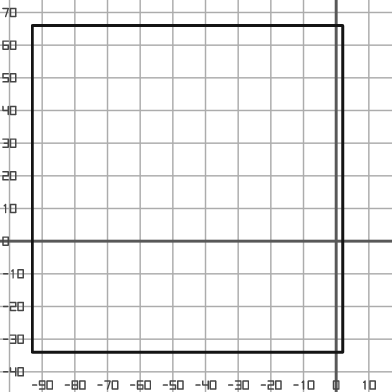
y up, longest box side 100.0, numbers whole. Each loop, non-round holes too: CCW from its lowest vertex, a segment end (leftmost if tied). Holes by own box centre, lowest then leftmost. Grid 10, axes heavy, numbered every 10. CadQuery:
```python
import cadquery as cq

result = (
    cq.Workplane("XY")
    .moveTo(-93.0, -34.0)
    .lineTo(2.0, -34.0)
    .lineTo(2.0, 66.0)
    .lineTo(-93.0, 66.0)
    .close()
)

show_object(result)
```